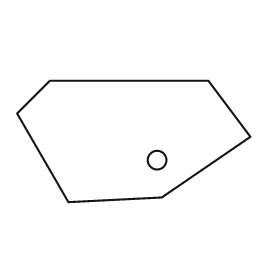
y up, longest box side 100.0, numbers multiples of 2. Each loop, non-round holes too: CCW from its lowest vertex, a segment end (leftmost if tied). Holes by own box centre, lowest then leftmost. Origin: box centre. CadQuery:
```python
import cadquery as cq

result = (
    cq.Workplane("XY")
    .moveTo(-28.0, -26.0)
    .lineTo(12.0, -24.0)
    .lineTo(50.0, 2.0)
    .lineTo(32.0, 26.0)
    .lineTo(-36.0, 26.0)
    .lineTo(-50.0, 12.0)
    .close()
    .moveTo(10.0, -8.0)
    .circle(4.0)
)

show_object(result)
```